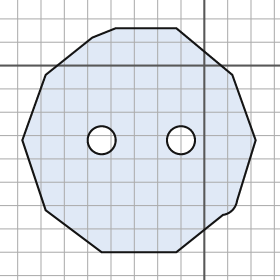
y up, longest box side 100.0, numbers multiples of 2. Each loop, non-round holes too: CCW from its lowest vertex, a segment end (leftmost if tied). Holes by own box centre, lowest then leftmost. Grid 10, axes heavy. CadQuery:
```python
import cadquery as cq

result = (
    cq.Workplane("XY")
    .moveTo(-44.0, -80.0)
    .lineTo(-12.0, -80.0)
    .lineTo(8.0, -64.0)
    .threePointArc((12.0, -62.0), (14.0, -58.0))
    .lineTo(22.0, -32.0)
    .lineTo(12.0, -4.0)
    .lineTo(-12.0, 16.0)
    .lineTo(-38.0, 16.0)
    .lineTo(-48.0, 12.0)
    .lineTo(-68.0, -4.0)
    .lineTo(-78.0, -32.0)
    .lineTo(-68.0, -62.0)
    .close()
    .moveTo(-44.0, -32.0)
    .circle(6.0)
    .moveTo(-10.0, -32.0)
    .circle(6.0)
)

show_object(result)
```